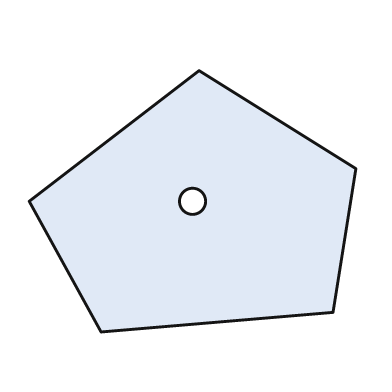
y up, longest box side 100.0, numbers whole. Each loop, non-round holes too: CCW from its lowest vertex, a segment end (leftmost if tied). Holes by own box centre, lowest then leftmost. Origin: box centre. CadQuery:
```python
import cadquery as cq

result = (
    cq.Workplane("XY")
    .moveTo(-28.0, -40.0)
    .lineTo(43.0, -34.0)
    .lineTo(50.0, 10.0)
    .lineTo(2.0, 40.0)
    .lineTo(-50.0, 0.0)
    .close()
    .moveTo(0.0, 0.0)
    .circle(4.0)
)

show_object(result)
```